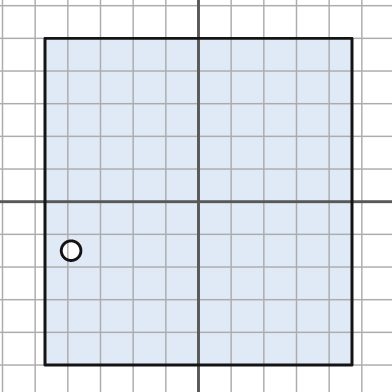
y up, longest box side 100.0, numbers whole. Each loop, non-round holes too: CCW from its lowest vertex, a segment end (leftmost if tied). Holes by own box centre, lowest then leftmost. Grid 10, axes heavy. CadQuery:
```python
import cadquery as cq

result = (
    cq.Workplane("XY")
    .moveTo(-47.0, -50.0)
    .lineTo(47.0, -50.0)
    .lineTo(47.0, 50.0)
    .lineTo(-47.0, 50.0)
    .close()
    .moveTo(-39.0, -15.0)
    .circle(3.0)
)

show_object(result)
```